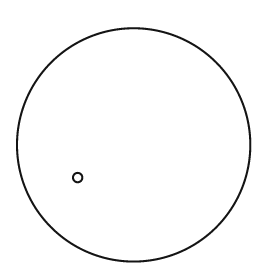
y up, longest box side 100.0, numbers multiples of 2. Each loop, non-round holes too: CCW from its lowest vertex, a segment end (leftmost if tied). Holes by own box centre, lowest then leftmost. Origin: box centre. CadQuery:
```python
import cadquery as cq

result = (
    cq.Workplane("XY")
    .moveTo(0.0, 0.0)
    .circle(50.0)
    .moveTo(-24.0, -14.0)
    .circle(2.0)
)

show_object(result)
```